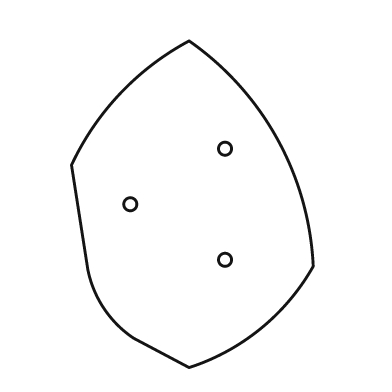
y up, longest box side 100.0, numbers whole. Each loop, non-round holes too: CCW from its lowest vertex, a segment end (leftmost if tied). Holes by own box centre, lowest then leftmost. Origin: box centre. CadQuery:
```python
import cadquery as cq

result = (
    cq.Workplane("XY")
    .moveTo(-1.0, -50.0)
    .threePointArc((21.0, -38.0), (37.0, -19.0))
    .threePointArc((26.0, 20.0), (-1.0, 50.0))
    .threePointArc((-22.0, 34.0), (-37.0, 12.0))
    .lineTo(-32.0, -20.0)
    .threePointArc((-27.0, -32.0), (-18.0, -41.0))
    .close()
    .moveTo(10.0, -17.0)
    .circle(2.0)
    .moveTo(-19.0, 0.0)
    .circle(2.0)
    .moveTo(10.0, 17.0)
    .circle(2.0)
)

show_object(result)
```